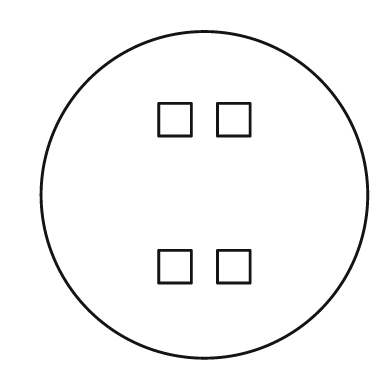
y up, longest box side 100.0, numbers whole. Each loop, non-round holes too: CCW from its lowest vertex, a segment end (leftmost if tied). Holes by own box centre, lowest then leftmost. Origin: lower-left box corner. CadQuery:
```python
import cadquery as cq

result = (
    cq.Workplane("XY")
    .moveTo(50.0, 50.0)
    .circle(50.0)
    .moveTo(36.0, 23.0)
    .lineTo(46.0, 23.0)
    .lineTo(46.0, 33.0)
    .lineTo(36.0, 33.0)
    .close()
    .moveTo(54.0, 23.0)
    .lineTo(64.0, 23.0)
    .lineTo(64.0, 33.0)
    .lineTo(54.0, 33.0)
    .close()
    .moveTo(36.0, 68.0)
    .lineTo(46.0, 68.0)
    .lineTo(46.0, 78.0)
    .lineTo(36.0, 78.0)
    .close()
    .moveTo(54.0, 68.0)
    .lineTo(64.0, 68.0)
    .lineTo(64.0, 78.0)
    .lineTo(54.0, 78.0)
    .close()
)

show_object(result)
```